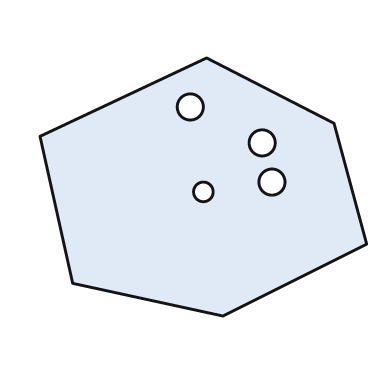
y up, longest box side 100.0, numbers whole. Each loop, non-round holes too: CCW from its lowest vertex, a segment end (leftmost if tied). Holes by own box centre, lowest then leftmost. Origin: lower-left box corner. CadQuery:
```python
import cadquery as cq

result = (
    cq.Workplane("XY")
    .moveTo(56.0, 0.0)
    .lineTo(100.0, 22.0)
    .lineTo(90.0, 59.0)
    .lineTo(51.0, 79.0)
    .lineTo(0.0, 55.0)
    .lineTo(10.0, 10.0)
    .close()
    .moveTo(50.0, 38.0)
    .circle(3.0)
    .moveTo(71.0, 41.0)
    .circle(4.0)
    .moveTo(68.0, 53.0)
    .circle(4.0)
    .moveTo(46.0, 64.0)
    .circle(4.0)
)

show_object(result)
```